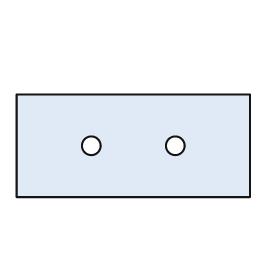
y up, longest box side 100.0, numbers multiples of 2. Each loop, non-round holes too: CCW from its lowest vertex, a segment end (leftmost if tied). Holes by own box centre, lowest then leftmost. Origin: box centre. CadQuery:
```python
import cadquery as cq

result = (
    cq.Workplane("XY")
    .moveTo(-50.0, -22.0)
    .lineTo(50.0, -22.0)
    .lineTo(50.0, 22.0)
    .lineTo(-50.0, 22.0)
    .close()
    .moveTo(-18.0, 0.0)
    .circle(4.0)
    .moveTo(18.0, 0.0)
    .circle(4.0)
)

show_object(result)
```